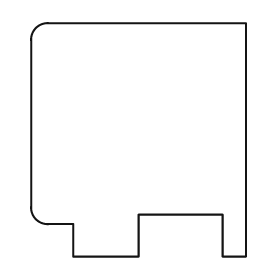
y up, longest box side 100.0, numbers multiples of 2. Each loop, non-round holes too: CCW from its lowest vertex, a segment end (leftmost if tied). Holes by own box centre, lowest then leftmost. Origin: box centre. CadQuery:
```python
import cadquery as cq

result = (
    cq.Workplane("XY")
    .moveTo(-28.0, -50.0)
    .lineTo(0.0, -50.0)
    .lineTo(0.0, -32.0)
    .lineTo(36.0, -32.0)
    .lineTo(36.0, -50.0)
    .lineTo(46.0, -50.0)
    .lineTo(46.0, 50.0)
    .lineTo(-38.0, 50.0)
    .threePointArc((-44.0, 48.0), (-46.0, 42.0))
    .lineTo(-46.0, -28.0)
    .threePointArc((-44.0, -34.0), (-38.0, -36.0))
    .lineTo(-28.0, -36.0)
    .close()
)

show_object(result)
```